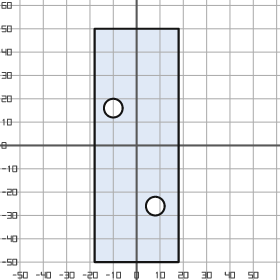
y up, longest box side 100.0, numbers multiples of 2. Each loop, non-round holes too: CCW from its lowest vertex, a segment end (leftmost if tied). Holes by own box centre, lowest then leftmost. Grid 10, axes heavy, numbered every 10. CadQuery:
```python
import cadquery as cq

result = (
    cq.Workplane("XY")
    .moveTo(-18.0, -50.0)
    .lineTo(18.0, -50.0)
    .lineTo(18.0, 50.0)
    .lineTo(-18.0, 50.0)
    .close()
    .moveTo(8.0, -26.0)
    .circle(4.0)
    .moveTo(-10.0, 16.0)
    .circle(4.0)
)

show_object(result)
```